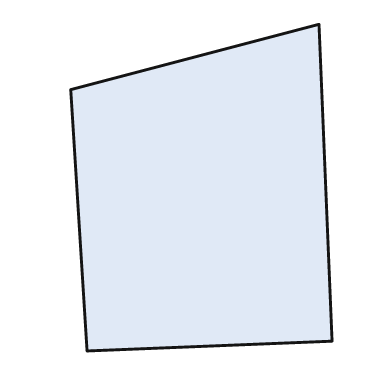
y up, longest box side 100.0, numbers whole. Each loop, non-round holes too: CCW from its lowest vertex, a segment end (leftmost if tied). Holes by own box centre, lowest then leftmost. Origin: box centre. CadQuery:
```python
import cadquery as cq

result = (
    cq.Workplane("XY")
    .moveTo(-35.0, -50.0)
    .lineTo(40.0, -47.0)
    .lineTo(36.0, 50.0)
    .lineTo(-40.0, 30.0)
    .close()
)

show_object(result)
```